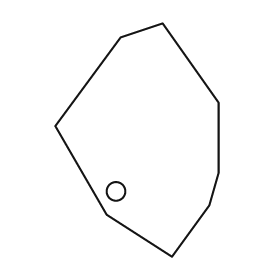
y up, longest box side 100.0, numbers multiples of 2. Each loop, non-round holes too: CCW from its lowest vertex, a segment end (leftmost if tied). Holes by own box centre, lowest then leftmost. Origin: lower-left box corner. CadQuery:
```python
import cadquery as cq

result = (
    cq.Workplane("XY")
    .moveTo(50.0, 0.0)
    .lineTo(66.0, 22.0)
    .lineTo(70.0, 36.0)
    .lineTo(70.0, 66.0)
    .lineTo(46.0, 100.0)
    .lineTo(28.0, 94.0)
    .lineTo(0.0, 56.0)
    .lineTo(22.0, 18.0)
    .close()
    .moveTo(26.0, 28.0)
    .circle(4.0)
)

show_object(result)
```